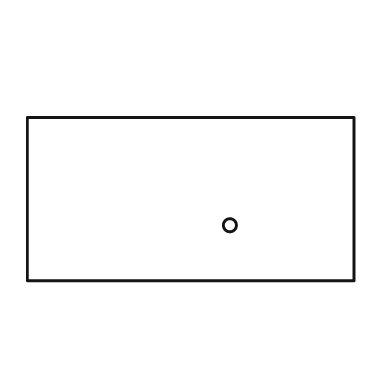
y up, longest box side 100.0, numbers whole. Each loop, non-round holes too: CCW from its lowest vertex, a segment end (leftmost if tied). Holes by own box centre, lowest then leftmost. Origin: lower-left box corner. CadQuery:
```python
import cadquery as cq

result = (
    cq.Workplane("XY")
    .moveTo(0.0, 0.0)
    .lineTo(100.0, 0.0)
    .lineTo(100.0, 50.0)
    .lineTo(0.0, 50.0)
    .close()
    .moveTo(62.0, 17.0)
    .circle(2.0)
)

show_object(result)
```